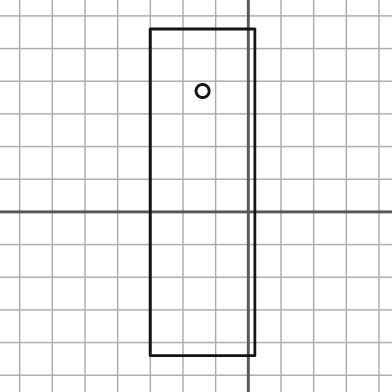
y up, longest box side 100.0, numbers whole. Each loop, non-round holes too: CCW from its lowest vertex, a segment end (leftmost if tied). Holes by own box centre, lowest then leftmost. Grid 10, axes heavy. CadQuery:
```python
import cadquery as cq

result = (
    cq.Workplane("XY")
    .moveTo(-30.0, -44.0)
    .lineTo(2.0, -44.0)
    .lineTo(2.0, 56.0)
    .lineTo(-30.0, 56.0)
    .close()
    .moveTo(-14.0, 37.0)
    .circle(2.0)
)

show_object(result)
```